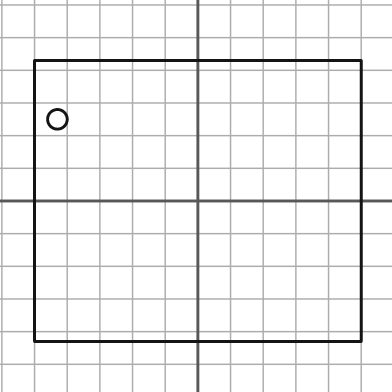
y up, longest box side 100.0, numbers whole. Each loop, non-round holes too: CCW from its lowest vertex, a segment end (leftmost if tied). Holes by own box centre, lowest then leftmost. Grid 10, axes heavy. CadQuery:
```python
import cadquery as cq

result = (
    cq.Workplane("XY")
    .moveTo(-50.0, -43.0)
    .lineTo(50.0, -43.0)
    .lineTo(50.0, 43.0)
    .lineTo(-50.0, 43.0)
    .close()
    .moveTo(-43.0, 25.0)
    .circle(3.0)
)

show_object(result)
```